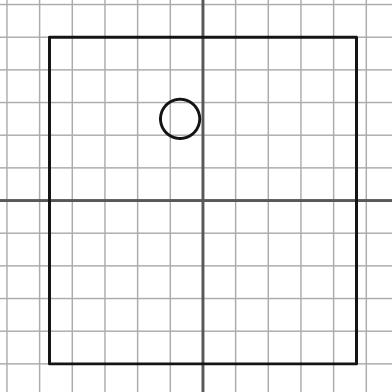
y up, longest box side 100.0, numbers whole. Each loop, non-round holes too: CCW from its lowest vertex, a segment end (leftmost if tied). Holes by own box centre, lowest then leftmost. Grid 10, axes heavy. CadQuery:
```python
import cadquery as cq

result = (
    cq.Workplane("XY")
    .moveTo(-47.0, -50.0)
    .lineTo(47.0, -50.0)
    .lineTo(47.0, 50.0)
    .lineTo(-47.0, 50.0)
    .close()
    .moveTo(-7.0, 25.0)
    .circle(6.0)
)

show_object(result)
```